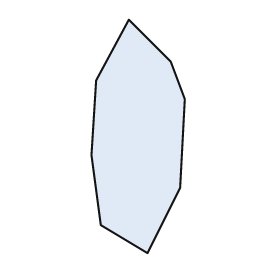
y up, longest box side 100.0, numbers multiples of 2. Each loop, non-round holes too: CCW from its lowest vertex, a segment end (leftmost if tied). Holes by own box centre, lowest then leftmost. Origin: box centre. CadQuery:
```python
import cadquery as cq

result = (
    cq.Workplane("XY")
    .moveTo(4.0, -50.0)
    .lineTo(18.0, -22.0)
    .lineTo(20.0, 16.0)
    .lineTo(14.0, 32.0)
    .lineTo(-4.0, 50.0)
    .lineTo(-18.0, 24.0)
    .lineTo(-20.0, -8.0)
    .lineTo(-16.0, -38.0)
    .close()
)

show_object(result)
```